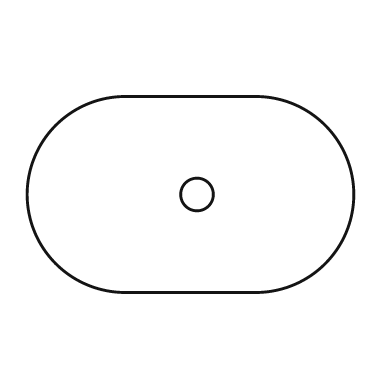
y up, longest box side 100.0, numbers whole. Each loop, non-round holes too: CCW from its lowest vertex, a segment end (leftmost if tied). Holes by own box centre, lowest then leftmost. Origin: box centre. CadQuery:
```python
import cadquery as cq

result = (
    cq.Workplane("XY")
    .moveTo(-20.0, -30.0)
    .lineTo(20.0, -30.0)
    .threePointArc((50.0, 0.0), (20.0, 30.0))
    .lineTo(-20.0, 30.0)
    .threePointArc((-50.0, 0.0), (-20.0, -30.0))
    .close()
    .moveTo(2.0, 0.0)
    .circle(5.0)
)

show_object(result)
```